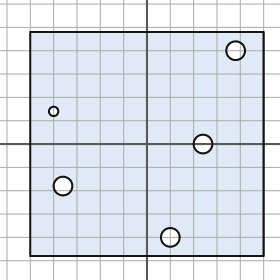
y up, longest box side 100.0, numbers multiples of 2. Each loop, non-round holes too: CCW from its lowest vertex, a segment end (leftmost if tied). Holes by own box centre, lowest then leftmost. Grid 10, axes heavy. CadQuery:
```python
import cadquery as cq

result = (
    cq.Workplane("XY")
    .moveTo(-50.0, -48.0)
    .lineTo(50.0, -48.0)
    .lineTo(50.0, 48.0)
    .lineTo(-50.0, 48.0)
    .close()
    .moveTo(10.0, -40.0)
    .circle(4.0)
    .moveTo(-36.0, -18.0)
    .circle(4.0)
    .moveTo(24.0, 0.0)
    .circle(4.0)
    .moveTo(-40.0, 14.0)
    .circle(2.0)
    .moveTo(38.0, 40.0)
    .circle(4.0)
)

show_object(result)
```